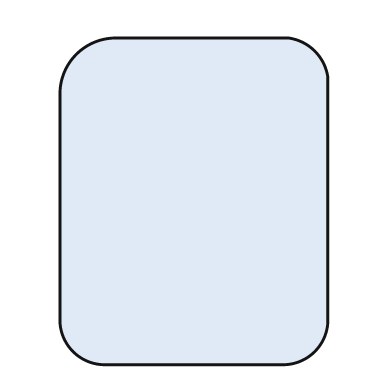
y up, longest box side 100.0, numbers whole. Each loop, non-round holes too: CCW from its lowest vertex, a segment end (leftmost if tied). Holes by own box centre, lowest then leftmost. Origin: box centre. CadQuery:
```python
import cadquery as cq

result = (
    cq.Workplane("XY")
    .moveTo(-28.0, -50.0)
    .lineTo(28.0, -50.0)
    .threePointArc((37.0, -46.0), (41.0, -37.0))
    .lineTo(41.0, 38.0)
    .threePointArc((37.0, 46.0), (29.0, 50.0))
    .lineTo(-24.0, 50.0)
    .threePointArc((-36.0, 45.0), (-41.0, 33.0))
    .lineTo(-41.0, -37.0)
    .threePointArc((-37.0, -46.0), (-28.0, -50.0))
    .close()
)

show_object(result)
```